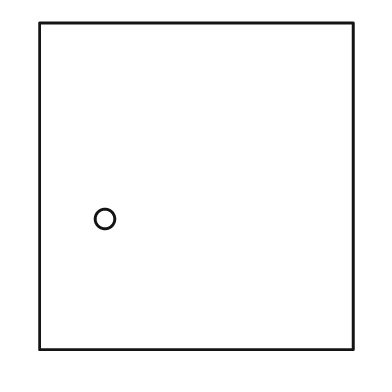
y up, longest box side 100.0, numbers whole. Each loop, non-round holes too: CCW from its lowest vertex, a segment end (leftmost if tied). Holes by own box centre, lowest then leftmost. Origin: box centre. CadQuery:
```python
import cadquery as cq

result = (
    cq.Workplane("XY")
    .moveTo(-48.0, -50.0)
    .lineTo(48.0, -50.0)
    .lineTo(48.0, 50.0)
    .lineTo(-48.0, 50.0)
    .close()
    .moveTo(-28.0, -10.0)
    .circle(3.0)
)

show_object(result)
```